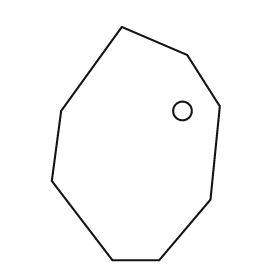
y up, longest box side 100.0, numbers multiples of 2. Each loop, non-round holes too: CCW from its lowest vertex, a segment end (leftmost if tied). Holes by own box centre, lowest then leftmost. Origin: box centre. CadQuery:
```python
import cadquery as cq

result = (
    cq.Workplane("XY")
    .moveTo(-10.0, -50.0)
    .lineTo(10.0, -50.0)
    .lineTo(32.0, -24.0)
    .lineTo(36.0, 16.0)
    .lineTo(22.0, 38.0)
    .lineTo(-6.0, 50.0)
    .lineTo(-32.0, 14.0)
    .lineTo(-36.0, -16.0)
    .close()
    .moveTo(20.0, 14.0)
    .circle(4.0)
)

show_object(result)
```